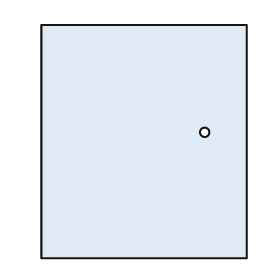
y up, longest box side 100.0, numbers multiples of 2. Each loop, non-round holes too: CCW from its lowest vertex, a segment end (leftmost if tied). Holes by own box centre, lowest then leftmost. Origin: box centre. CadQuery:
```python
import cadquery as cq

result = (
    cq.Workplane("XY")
    .moveTo(-44.0, -50.0)
    .lineTo(44.0, -50.0)
    .lineTo(44.0, 50.0)
    .lineTo(-44.0, 50.0)
    .close()
    .moveTo(26.0, 4.0)
    .circle(2.0)
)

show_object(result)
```